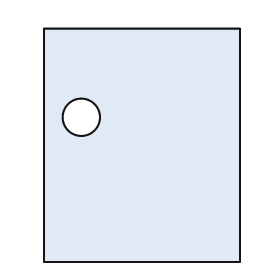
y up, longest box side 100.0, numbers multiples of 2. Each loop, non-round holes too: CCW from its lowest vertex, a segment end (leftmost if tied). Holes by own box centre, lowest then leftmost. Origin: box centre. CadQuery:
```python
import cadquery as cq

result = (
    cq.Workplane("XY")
    .moveTo(-42.0, -50.0)
    .lineTo(42.0, -50.0)
    .lineTo(42.0, 50.0)
    .lineTo(-42.0, 50.0)
    .close()
    .moveTo(-26.0, 12.0)
    .circle(8.0)
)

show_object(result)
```